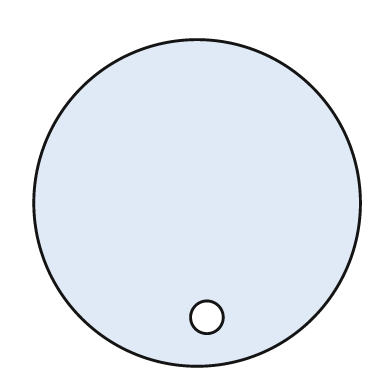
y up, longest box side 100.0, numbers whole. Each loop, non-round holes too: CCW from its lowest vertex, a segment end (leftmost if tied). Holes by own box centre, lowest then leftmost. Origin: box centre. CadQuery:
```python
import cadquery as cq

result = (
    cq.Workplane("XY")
    .moveTo(0.0, 0.0)
    .circle(50.0)
    .moveTo(3.0, -35.0)
    .circle(5.0)
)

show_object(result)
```